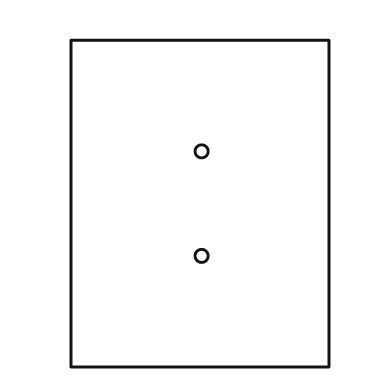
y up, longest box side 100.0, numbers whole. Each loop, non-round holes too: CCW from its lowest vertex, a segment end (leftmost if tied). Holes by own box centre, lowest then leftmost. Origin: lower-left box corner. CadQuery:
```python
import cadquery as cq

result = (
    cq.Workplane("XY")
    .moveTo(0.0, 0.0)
    .lineTo(79.0, 0.0)
    .lineTo(79.0, 100.0)
    .lineTo(0.0, 100.0)
    .close()
    .moveTo(40.0, 34.0)
    .circle(2.0)
    .moveTo(40.0, 66.0)
    .circle(2.0)
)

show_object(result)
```